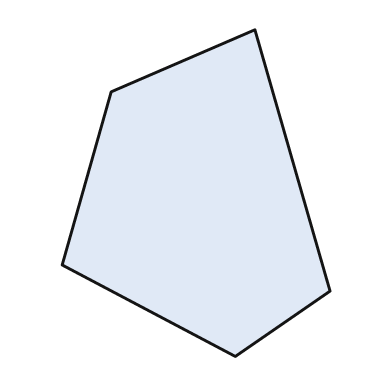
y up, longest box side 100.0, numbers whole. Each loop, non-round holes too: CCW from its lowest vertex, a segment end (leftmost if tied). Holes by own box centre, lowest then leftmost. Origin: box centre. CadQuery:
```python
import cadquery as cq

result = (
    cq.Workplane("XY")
    .moveTo(12.0, -50.0)
    .lineTo(41.0, -30.0)
    .lineTo(18.0, 50.0)
    .lineTo(-26.0, 31.0)
    .lineTo(-41.0, -22.0)
    .close()
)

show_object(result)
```